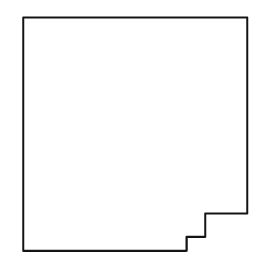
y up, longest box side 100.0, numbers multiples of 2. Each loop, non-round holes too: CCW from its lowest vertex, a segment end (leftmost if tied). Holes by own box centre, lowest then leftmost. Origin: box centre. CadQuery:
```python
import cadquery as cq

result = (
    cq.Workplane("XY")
    .moveTo(-48.0, -50.0)
    .lineTo(22.0, -50.0)
    .lineTo(22.0, -44.0)
    .lineTo(30.0, -44.0)
    .lineTo(30.0, -34.0)
    .lineTo(48.0, -34.0)
    .lineTo(48.0, 50.0)
    .lineTo(-48.0, 50.0)
    .close()
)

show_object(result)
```